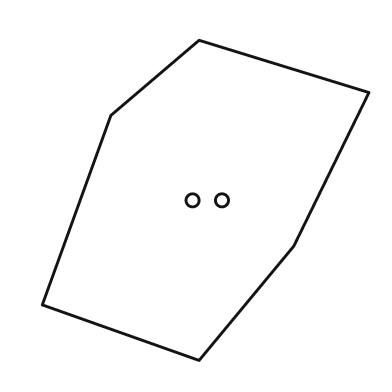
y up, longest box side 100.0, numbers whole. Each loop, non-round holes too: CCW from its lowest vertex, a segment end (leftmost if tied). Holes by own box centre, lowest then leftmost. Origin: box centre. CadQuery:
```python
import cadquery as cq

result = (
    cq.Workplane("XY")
    .moveTo(-2.0, -49.0)
    .lineTo(27.0, -14.0)
    .lineTo(50.0, 33.0)
    .lineTo(-2.0, 49.0)
    .lineTo(-29.0, 26.0)
    .lineTo(-50.0, -32.0)
    .close()
    .moveTo(-4.0, 0.0)
    .circle(2.0)
    .moveTo(5.0, 0.0)
    .circle(2.0)
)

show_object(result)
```